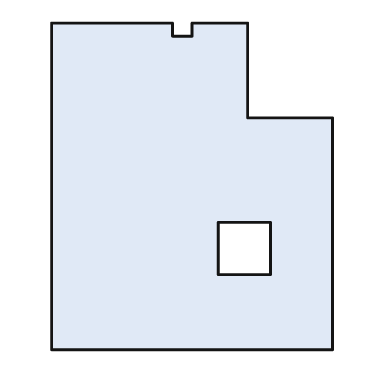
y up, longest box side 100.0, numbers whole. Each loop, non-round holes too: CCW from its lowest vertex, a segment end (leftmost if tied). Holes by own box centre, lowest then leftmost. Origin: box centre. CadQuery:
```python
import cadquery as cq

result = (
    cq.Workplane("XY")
    .moveTo(-43.0, -50.0)
    .lineTo(43.0, -50.0)
    .lineTo(43.0, 21.0)
    .lineTo(17.0, 21.0)
    .lineTo(17.0, 50.0)
    .lineTo(0.0, 50.0)
    .lineTo(0.0, 46.0)
    .lineTo(-6.0, 46.0)
    .lineTo(-6.0, 50.0)
    .lineTo(-43.0, 50.0)
    .close()
    .moveTo(8.0, -27.0)
    .lineTo(24.0, -27.0)
    .lineTo(24.0, -11.0)
    .lineTo(8.0, -11.0)
    .close()
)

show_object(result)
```